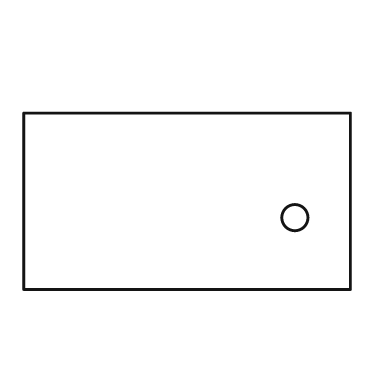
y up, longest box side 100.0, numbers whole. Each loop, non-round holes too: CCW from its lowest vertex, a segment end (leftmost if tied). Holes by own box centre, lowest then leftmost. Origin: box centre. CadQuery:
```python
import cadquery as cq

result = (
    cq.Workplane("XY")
    .moveTo(-50.0, -27.0)
    .lineTo(50.0, -27.0)
    .lineTo(50.0, 27.0)
    .lineTo(-50.0, 27.0)
    .close()
    .moveTo(33.0, -5.0)
    .circle(4.0)
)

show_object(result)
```